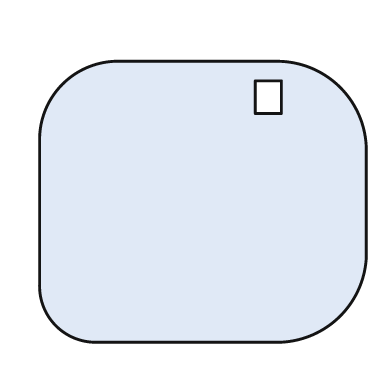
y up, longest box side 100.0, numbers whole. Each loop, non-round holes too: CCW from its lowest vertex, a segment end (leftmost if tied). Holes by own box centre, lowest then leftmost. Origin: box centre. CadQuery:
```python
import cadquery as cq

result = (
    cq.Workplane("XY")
    .moveTo(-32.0, -43.0)
    .lineTo(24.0, -43.0)
    .threePointArc((42.0, -35.0), (50.0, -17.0))
    .lineTo(50.0, 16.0)
    .threePointArc((42.0, 35.0), (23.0, 43.0))
    .lineTo(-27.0, 43.0)
    .threePointArc((-43.0, 36.0), (-50.0, 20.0))
    .lineTo(-50.0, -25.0)
    .threePointArc((-45.0, -38.0), (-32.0, -43.0))
    .close()
    .moveTo(16.0, 27.0)
    .lineTo(24.0, 27.0)
    .lineTo(24.0, 37.0)
    .lineTo(16.0, 37.0)
    .close()
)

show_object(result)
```